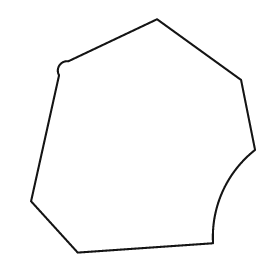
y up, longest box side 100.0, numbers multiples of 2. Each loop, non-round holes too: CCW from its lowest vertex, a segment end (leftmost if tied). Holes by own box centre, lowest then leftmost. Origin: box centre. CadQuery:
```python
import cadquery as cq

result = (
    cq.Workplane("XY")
    .moveTo(-28.0, -50.0)
    .lineTo(30.0, -46.0)
    .threePointArc((34.0, -24.0), (48.0, -6.0))
    .lineTo(42.0, 24.0)
    .lineTo(6.0, 50.0)
    .lineTo(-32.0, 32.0)
    .threePointArc((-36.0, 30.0), (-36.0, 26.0))
    .lineTo(-48.0, -28.0)
    .close()
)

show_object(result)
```